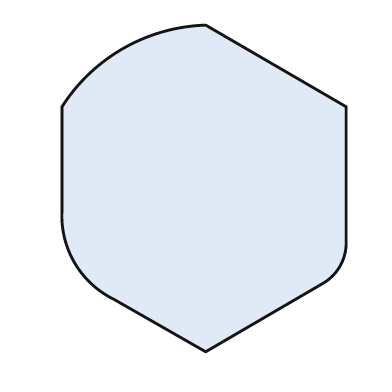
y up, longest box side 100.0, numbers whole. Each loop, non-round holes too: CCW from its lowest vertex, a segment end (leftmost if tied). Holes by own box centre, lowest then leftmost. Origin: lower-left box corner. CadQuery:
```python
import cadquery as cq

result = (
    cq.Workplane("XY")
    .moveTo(44.0, 0.0)
    .lineTo(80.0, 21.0)
    .threePointArc((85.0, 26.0), (87.0, 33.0))
    .lineTo(87.0, 75.0)
    .lineTo(44.0, 100.0)
    .threePointArc((19.0, 93.0), (0.0, 75.0))
    .lineTo(0.0, 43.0)
    .threePointArc((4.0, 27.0), (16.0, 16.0))
    .close()
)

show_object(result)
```